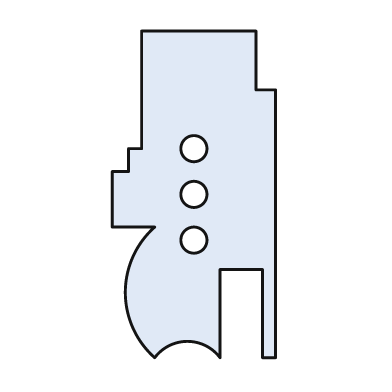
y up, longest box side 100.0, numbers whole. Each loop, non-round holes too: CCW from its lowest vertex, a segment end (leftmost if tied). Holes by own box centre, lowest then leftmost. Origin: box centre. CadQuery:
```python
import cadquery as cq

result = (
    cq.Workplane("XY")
    .moveTo(-12.0, -50.0)
    .threePointArc((-2.0, -45.0), (8.0, -50.0))
    .lineTo(8.0, -23.0)
    .lineTo(21.0, -23.0)
    .lineTo(21.0, -50.0)
    .lineTo(25.0, -50.0)
    .lineTo(25.0, 32.0)
    .lineTo(19.0, 32.0)
    .lineTo(19.0, 50.0)
    .lineTo(-16.0, 50.0)
    .lineTo(-16.0, 14.0)
    .lineTo(-20.0, 14.0)
    .lineTo(-20.0, 7.0)
    .lineTo(-25.0, 7.0)
    .lineTo(-25.0, -10.0)
    .lineTo(-12.0, -10.0)
    .threePointArc((-21.0, -30.0), (-12.0, -50.0))
    .close()
    .moveTo(0.0, -14.0)
    .circle(4.0)
    .moveTo(0.0, 0.0)
    .circle(4.0)
    .moveTo(0.0, 14.0)
    .circle(4.0)
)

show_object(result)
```